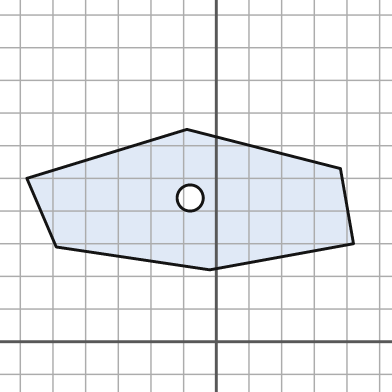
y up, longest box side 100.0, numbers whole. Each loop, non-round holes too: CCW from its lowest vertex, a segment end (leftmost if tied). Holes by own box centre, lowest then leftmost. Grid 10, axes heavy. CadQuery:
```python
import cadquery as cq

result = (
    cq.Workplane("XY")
    .moveTo(-2.0, 22.0)
    .lineTo(42.0, 30.0)
    .lineTo(38.0, 53.0)
    .lineTo(-9.0, 65.0)
    .lineTo(-58.0, 50.0)
    .lineTo(-49.0, 29.0)
    .close()
    .moveTo(-8.0, 44.0)
    .circle(4.0)
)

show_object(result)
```